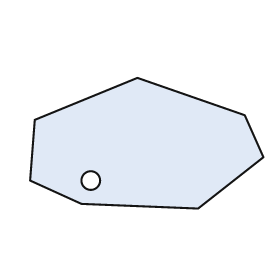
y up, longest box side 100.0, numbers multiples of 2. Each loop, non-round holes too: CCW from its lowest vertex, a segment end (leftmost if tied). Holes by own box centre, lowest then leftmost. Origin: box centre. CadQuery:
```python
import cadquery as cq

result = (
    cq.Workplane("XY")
    .moveTo(22.0, -28.0)
    .lineTo(50.0, -6.0)
    .lineTo(42.0, 12.0)
    .lineTo(-4.0, 28.0)
    .lineTo(-48.0, 10.0)
    .lineTo(-50.0, -16.0)
    .lineTo(-28.0, -26.0)
    .close()
    .moveTo(-24.0, -16.0)
    .circle(4.0)
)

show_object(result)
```